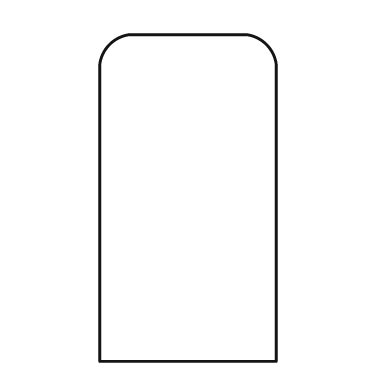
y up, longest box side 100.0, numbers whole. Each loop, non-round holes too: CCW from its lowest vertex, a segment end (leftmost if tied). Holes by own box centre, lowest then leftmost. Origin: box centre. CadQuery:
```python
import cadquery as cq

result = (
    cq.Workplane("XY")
    .moveTo(-27.0, -50.0)
    .lineTo(27.0, -50.0)
    .lineTo(27.0, 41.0)
    .threePointArc((24.0, 47.0), (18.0, 50.0))
    .lineTo(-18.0, 50.0)
    .threePointArc((-24.0, 47.0), (-27.0, 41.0))
    .close()
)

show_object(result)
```